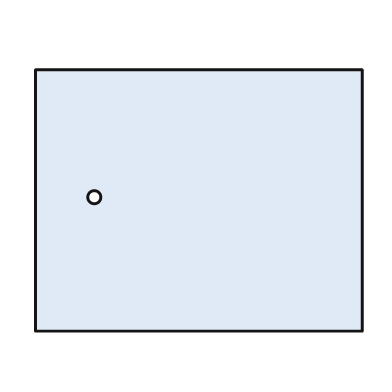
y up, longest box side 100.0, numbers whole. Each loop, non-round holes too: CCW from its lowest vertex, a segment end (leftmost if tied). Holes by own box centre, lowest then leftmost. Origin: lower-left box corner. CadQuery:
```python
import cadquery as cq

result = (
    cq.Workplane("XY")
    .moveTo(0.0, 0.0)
    .lineTo(100.0, 0.0)
    .lineTo(100.0, 80.0)
    .lineTo(0.0, 80.0)
    .close()
    .moveTo(18.0, 41.0)
    .circle(2.0)
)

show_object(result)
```